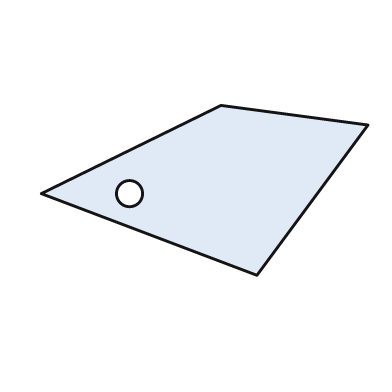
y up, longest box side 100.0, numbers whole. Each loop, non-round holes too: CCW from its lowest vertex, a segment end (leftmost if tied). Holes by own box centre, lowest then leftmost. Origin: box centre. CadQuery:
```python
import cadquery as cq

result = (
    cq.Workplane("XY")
    .moveTo(16.0, -26.0)
    .lineTo(50.0, 20.0)
    .lineTo(5.0, 26.0)
    .lineTo(-50.0, -1.0)
    .close()
    .moveTo(-23.0, -1.0)
    .circle(4.0)
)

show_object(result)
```